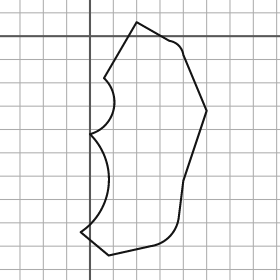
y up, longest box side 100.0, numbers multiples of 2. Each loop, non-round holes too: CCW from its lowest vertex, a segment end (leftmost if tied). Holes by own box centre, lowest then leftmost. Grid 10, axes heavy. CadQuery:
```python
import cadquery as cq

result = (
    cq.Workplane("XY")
    .moveTo(8.0, -94.0)
    .lineTo(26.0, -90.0)
    .threePointArc((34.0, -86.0), (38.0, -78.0))
    .lineTo(40.0, -62.0)
    .lineTo(50.0, -32.0)
    .lineTo(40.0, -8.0)
    .threePointArc((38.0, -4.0), (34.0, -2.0))
    .lineTo(20.0, 6.0)
    .lineTo(6.0, -18.0)
    .threePointArc((10.0, -32.0), (0.0, -42.0))
    .threePointArc((8.0, -64.0), (-4.0, -84.0))
    .close()
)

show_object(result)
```